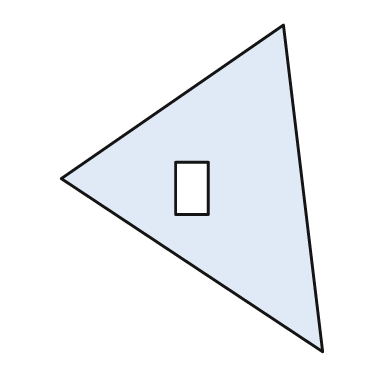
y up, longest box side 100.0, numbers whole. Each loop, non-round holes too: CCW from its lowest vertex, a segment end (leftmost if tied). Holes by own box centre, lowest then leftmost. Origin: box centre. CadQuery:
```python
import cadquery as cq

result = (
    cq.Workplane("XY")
    .moveTo(40.0, -50.0)
    .lineTo(28.0, 50.0)
    .lineTo(-40.0, 3.0)
    .close()
    .moveTo(-5.0, -8.0)
    .lineTo(5.0, -8.0)
    .lineTo(5.0, 8.0)
    .lineTo(-5.0, 8.0)
    .close()
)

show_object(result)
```